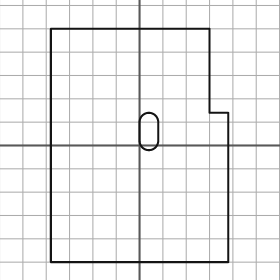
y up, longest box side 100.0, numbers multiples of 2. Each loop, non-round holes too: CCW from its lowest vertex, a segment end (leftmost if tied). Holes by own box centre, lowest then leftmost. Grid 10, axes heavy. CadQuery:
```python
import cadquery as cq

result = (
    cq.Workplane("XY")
    .moveTo(-38.0, -50.0)
    .lineTo(38.0, -50.0)
    .lineTo(38.0, 14.0)
    .lineTo(30.0, 14.0)
    .lineTo(30.0, 50.0)
    .lineTo(-38.0, 50.0)
    .close()
    .moveTo(0.0, 2.0)
    .threePointArc((4.0, -2.0), (8.0, 2.0))
    .lineTo(8.0, 10.0)
    .threePointArc((4.0, 14.0), (0.0, 10.0))
    .close()
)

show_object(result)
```